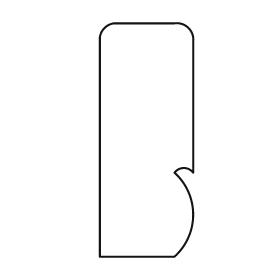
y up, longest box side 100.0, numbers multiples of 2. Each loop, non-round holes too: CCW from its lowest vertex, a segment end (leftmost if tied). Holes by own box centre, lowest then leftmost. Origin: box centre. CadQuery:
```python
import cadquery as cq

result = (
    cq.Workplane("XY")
    .moveTo(-20.0, -50.0)
    .lineTo(12.0, -50.0)
    .threePointArc((20.0, -32.0), (12.0, -14.0))
    .threePointArc((16.0, -12.0), (20.0, -14.0))
    .lineTo(20.0, 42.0)
    .threePointArc((18.0, 48.0), (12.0, 50.0))
    .lineTo(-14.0, 50.0)
    .threePointArc((-18.0, 48.0), (-20.0, 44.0))
    .close()
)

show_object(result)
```